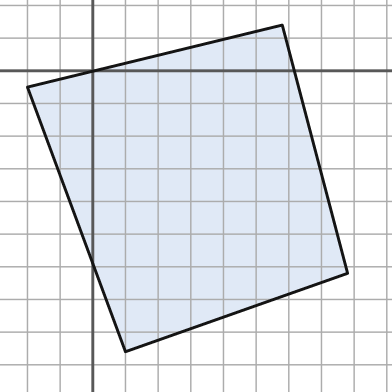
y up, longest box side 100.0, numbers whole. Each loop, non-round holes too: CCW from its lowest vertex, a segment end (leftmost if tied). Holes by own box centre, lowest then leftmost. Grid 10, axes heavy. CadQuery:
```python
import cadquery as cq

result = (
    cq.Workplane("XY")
    .moveTo(10.0, -86.0)
    .lineTo(78.0, -62.0)
    .lineTo(58.0, 14.0)
    .lineTo(-20.0, -5.0)
    .close()
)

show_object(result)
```